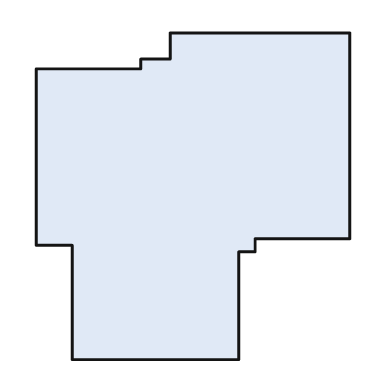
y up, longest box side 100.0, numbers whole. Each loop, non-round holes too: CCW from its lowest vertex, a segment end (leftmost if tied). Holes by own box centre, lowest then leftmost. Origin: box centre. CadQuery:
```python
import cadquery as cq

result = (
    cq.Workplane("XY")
    .moveTo(-37.0, -50.0)
    .lineTo(14.0, -50.0)
    .lineTo(14.0, -17.0)
    .lineTo(19.0, -17.0)
    .lineTo(19.0, -13.0)
    .lineTo(48.0, -13.0)
    .lineTo(48.0, 50.0)
    .lineTo(-7.0, 50.0)
    .lineTo(-7.0, 42.0)
    .lineTo(-16.0, 42.0)
    .lineTo(-16.0, 39.0)
    .lineTo(-48.0, 39.0)
    .lineTo(-48.0, -15.0)
    .lineTo(-37.0, -15.0)
    .close()
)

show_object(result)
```